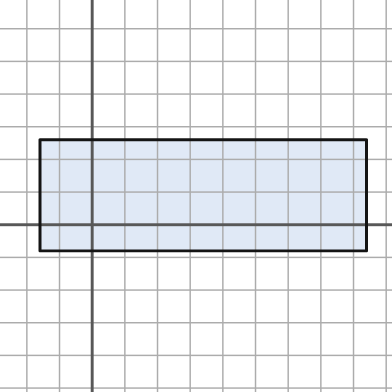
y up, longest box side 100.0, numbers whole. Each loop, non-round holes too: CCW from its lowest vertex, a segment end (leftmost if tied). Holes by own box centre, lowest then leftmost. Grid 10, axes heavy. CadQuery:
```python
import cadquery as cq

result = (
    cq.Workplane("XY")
    .moveTo(-16.0, -8.0)
    .lineTo(84.0, -8.0)
    .lineTo(84.0, 26.0)
    .lineTo(-16.0, 26.0)
    .close()
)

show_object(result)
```